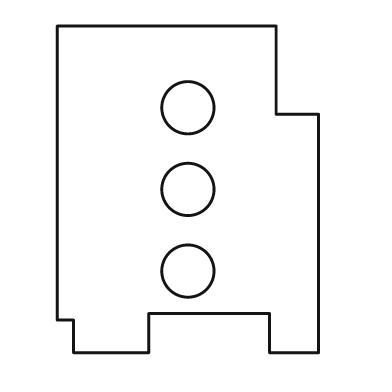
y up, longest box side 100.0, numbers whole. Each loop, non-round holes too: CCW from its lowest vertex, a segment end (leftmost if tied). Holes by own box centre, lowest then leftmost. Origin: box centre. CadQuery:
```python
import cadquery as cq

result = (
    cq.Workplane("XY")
    .moveTo(-35.0, -50.0)
    .lineTo(-12.0, -50.0)
    .lineTo(-12.0, -38.0)
    .lineTo(25.0, -38.0)
    .lineTo(25.0, -50.0)
    .lineTo(40.0, -50.0)
    .lineTo(40.0, 23.0)
    .lineTo(27.0, 23.0)
    .lineTo(27.0, 50.0)
    .lineTo(-40.0, 50.0)
    .lineTo(-40.0, -40.0)
    .lineTo(-35.0, -40.0)
    .close()
    .moveTo(0.0, -25.0)
    .circle(8.0)
    .moveTo(0.0, 0.0)
    .circle(8.0)
    .moveTo(0.0, 25.0)
    .circle(8.0)
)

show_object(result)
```